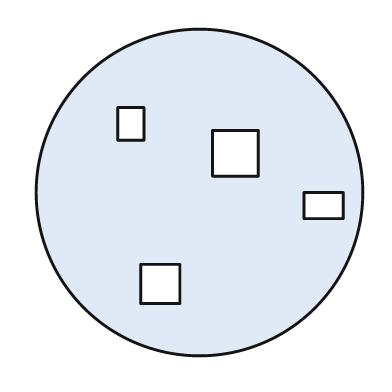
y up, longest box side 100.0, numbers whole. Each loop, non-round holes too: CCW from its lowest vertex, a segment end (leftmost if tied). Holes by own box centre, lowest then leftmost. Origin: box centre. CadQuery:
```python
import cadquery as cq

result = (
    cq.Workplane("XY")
    .moveTo(0.0, 0.0)
    .circle(50.0)
    .moveTo(-18.0, -34.0)
    .lineTo(-6.0, -34.0)
    .lineTo(-6.0, -22.0)
    .lineTo(-18.0, -22.0)
    .close()
    .moveTo(32.0, -8.0)
    .lineTo(44.0, -8.0)
    .lineTo(44.0, 0.0)
    .lineTo(32.0, 0.0)
    .close()
    .moveTo(4.0, 5.0)
    .lineTo(18.0, 5.0)
    .lineTo(18.0, 19.0)
    .lineTo(4.0, 19.0)
    .close()
    .moveTo(-25.0, 16.0)
    .lineTo(-17.0, 16.0)
    .lineTo(-17.0, 26.0)
    .lineTo(-25.0, 26.0)
    .close()
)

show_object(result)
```